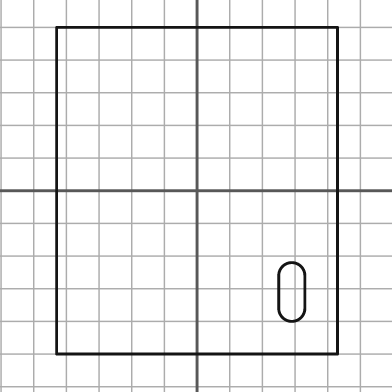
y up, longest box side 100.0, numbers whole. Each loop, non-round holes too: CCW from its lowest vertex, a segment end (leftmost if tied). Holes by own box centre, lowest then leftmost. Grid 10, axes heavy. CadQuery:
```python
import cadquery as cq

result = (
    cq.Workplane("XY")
    .moveTo(-43.0, -50.0)
    .lineTo(43.0, -50.0)
    .lineTo(43.0, 50.0)
    .lineTo(-43.0, 50.0)
    .close()
    .moveTo(25.0, -36.0)
    .threePointArc((29.0, -40.0), (33.0, -36.0))
    .lineTo(33.0, -26.0)
    .threePointArc((29.0, -22.0), (25.0, -26.0))
    .close()
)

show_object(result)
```